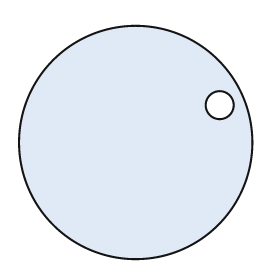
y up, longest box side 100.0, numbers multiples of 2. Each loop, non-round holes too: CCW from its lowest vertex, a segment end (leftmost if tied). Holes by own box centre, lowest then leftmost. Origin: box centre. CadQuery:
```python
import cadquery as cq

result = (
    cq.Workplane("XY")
    .moveTo(0.0, 0.0)
    .circle(50.0)
    .moveTo(36.0, 16.0)
    .circle(6.0)
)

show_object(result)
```